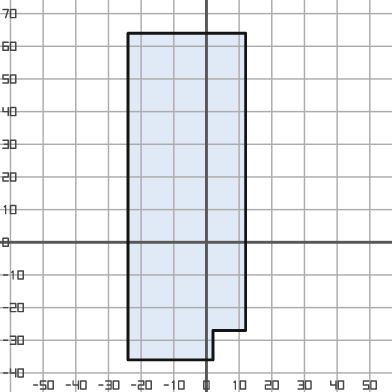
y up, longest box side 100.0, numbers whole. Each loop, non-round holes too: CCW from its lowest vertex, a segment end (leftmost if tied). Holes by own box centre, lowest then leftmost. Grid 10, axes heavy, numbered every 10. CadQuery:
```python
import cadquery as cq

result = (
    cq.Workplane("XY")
    .moveTo(-24.0, -36.0)
    .lineTo(2.0, -36.0)
    .lineTo(2.0, -27.0)
    .lineTo(12.0, -27.0)
    .lineTo(12.0, 64.0)
    .lineTo(-24.0, 64.0)
    .close()
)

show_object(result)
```